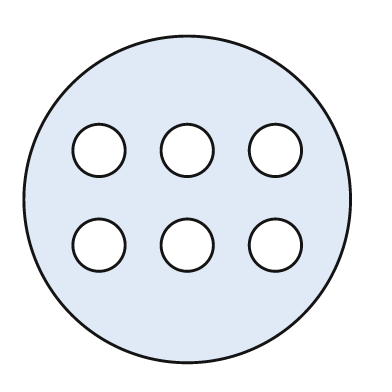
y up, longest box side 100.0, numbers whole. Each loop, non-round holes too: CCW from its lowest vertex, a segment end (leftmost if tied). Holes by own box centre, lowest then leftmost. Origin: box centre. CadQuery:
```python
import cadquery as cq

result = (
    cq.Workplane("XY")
    .moveTo(0.0, 0.0)
    .circle(50.0)
    .moveTo(-27.0, -14.0)
    .circle(8.0)
    .moveTo(0.0, -14.0)
    .circle(8.0)
    .moveTo(27.0, -14.0)
    .circle(8.0)
    .moveTo(-27.0, 15.0)
    .circle(8.0)
    .moveTo(0.0, 15.0)
    .circle(8.0)
    .moveTo(27.0, 15.0)
    .circle(8.0)
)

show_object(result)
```